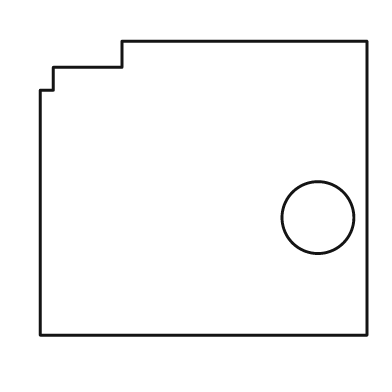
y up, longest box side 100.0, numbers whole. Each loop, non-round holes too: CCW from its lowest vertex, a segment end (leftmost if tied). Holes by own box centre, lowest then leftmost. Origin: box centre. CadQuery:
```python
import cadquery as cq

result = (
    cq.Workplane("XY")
    .moveTo(-50.0, -45.0)
    .lineTo(50.0, -45.0)
    .lineTo(50.0, 45.0)
    .lineTo(-25.0, 45.0)
    .lineTo(-25.0, 37.0)
    .lineTo(-46.0, 37.0)
    .lineTo(-46.0, 30.0)
    .lineTo(-50.0, 30.0)
    .close()
    .moveTo(35.0, -9.0)
    .circle(11.0)
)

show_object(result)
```